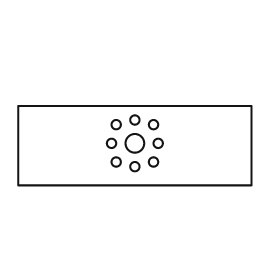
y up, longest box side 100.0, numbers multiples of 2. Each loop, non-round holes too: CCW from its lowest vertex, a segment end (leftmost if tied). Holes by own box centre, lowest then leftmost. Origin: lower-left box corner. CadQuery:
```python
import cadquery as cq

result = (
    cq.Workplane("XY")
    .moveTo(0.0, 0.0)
    .lineTo(100.0, 0.0)
    .lineTo(100.0, 34.0)
    .lineTo(0.0, 34.0)
    .close()
    .moveTo(50.0, 8.0)
    .circle(2.0)
    .moveTo(42.0, 10.0)
    .circle(2.0)
    .moveTo(58.0, 10.0)
    .circle(2.0)
    .moveTo(40.0, 18.0)
    .circle(2.0)
    .moveTo(50.0, 18.0)
    .circle(4.0)
    .moveTo(60.0, 18.0)
    .circle(2.0)
    .moveTo(42.0, 26.0)
    .circle(2.0)
    .moveTo(58.0, 26.0)
    .circle(2.0)
    .moveTo(50.0, 28.0)
    .circle(2.0)
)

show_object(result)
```